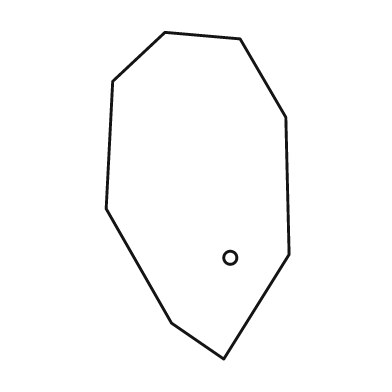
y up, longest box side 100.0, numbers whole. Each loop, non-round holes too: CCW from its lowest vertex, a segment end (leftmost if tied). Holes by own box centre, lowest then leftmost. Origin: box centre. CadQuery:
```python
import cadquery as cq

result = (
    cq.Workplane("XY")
    .moveTo(8.0, -50.0)
    .lineTo(28.0, -18.0)
    .lineTo(27.0, 24.0)
    .lineTo(13.0, 48.0)
    .lineTo(-10.0, 50.0)
    .lineTo(-26.0, 35.0)
    .lineTo(-28.0, -4.0)
    .lineTo(-8.0, -39.0)
    .close()
    .moveTo(10.0, -19.0)
    .circle(2.0)
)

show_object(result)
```